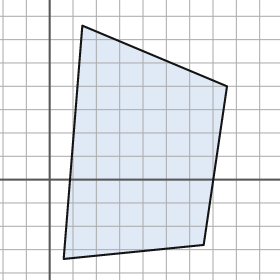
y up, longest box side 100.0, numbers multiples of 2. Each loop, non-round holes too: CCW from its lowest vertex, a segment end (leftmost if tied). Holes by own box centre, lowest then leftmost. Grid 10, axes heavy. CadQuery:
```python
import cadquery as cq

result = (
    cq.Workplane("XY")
    .moveTo(6.0, -34.0)
    .lineTo(66.0, -28.0)
    .lineTo(76.0, 40.0)
    .lineTo(14.0, 66.0)
    .close()
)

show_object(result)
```